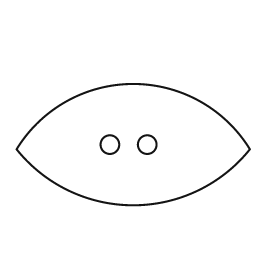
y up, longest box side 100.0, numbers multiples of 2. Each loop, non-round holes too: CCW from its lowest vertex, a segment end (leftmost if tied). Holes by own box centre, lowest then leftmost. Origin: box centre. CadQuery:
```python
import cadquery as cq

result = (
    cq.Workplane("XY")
    .moveTo(-50.0, -2.0)
    .threePointArc((0.0, -26.0), (50.0, -2.0))
    .threePointArc((0.0, 26.0), (-50.0, -2.0))
    .close()
    .moveTo(-10.0, 0.0)
    .circle(4.0)
    .moveTo(6.0, 0.0)
    .circle(4.0)
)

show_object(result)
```